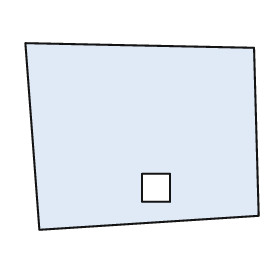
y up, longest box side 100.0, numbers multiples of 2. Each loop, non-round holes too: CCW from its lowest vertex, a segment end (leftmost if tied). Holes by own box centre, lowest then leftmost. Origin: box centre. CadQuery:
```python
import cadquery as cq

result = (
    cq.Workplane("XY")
    .moveTo(-44.0, -40.0)
    .lineTo(50.0, -34.0)
    .lineTo(48.0, 38.0)
    .lineTo(-50.0, 40.0)
    .close()
    .moveTo(0.0, -28.0)
    .lineTo(12.0, -28.0)
    .lineTo(12.0, -16.0)
    .lineTo(0.0, -16.0)
    .close()
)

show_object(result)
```